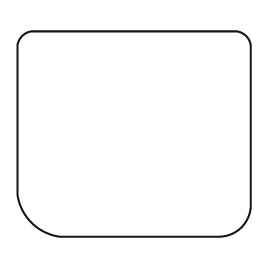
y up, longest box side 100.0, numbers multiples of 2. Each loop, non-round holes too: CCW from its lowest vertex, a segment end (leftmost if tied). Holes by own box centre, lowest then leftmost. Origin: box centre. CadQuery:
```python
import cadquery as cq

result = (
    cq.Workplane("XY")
    .moveTo(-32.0, -44.0)
    .lineTo(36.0, -44.0)
    .threePointArc((46.0, -40.0), (50.0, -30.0))
    .lineTo(50.0, 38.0)
    .threePointArc((48.0, 42.0), (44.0, 44.0))
    .lineTo(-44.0, 44.0)
    .threePointArc((-48.0, 42.0), (-50.0, 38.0))
    .lineTo(-50.0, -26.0)
    .threePointArc((-44.0, -38.0), (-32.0, -44.0))
    .close()
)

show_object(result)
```